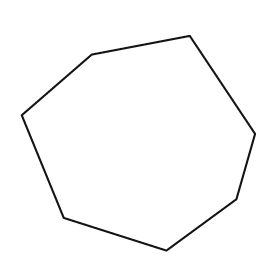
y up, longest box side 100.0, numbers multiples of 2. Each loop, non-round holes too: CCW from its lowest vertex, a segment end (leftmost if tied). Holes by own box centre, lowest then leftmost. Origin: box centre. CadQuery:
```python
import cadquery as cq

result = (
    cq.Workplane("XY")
    .moveTo(12.0, -46.0)
    .lineTo(42.0, -24.0)
    .lineTo(50.0, 4.0)
    .lineTo(22.0, 46.0)
    .lineTo(-20.0, 38.0)
    .lineTo(-50.0, 12.0)
    .lineTo(-32.0, -32.0)
    .close()
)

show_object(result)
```